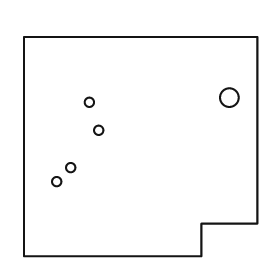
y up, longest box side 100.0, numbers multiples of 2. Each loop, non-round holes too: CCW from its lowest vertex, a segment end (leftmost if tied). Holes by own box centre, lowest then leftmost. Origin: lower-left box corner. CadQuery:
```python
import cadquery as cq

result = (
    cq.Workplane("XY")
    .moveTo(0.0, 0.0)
    .lineTo(76.0, 0.0)
    .lineTo(76.0, 14.0)
    .lineTo(100.0, 14.0)
    .lineTo(100.0, 94.0)
    .lineTo(0.0, 94.0)
    .close()
    .moveTo(14.0, 32.0)
    .circle(2.0)
    .moveTo(20.0, 38.0)
    .circle(2.0)
    .moveTo(32.0, 54.0)
    .circle(2.0)
    .moveTo(28.0, 66.0)
    .circle(2.0)
    .moveTo(88.0, 68.0)
    .circle(4.0)
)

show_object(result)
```